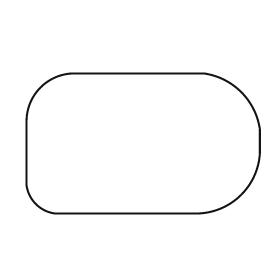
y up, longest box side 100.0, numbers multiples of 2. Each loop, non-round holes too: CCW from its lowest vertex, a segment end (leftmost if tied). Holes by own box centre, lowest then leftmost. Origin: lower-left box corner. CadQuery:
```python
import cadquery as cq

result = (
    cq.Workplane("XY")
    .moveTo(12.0, 0.0)
    .lineTo(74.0, 0.0)
    .threePointArc((92.0, 8.0), (100.0, 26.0))
    .lineTo(100.0, 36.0)
    .threePointArc((92.0, 52.0), (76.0, 60.0))
    .lineTo(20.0, 60.0)
    .threePointArc((6.0, 54.0), (0.0, 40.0))
    .lineTo(0.0, 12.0)
    .threePointArc((4.0, 4.0), (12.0, 0.0))
    .close()
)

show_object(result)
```